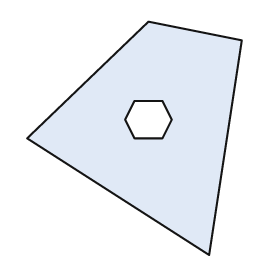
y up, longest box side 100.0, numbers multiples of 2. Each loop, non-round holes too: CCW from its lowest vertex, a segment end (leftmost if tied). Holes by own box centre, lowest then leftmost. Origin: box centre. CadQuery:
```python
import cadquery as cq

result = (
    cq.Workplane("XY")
    .moveTo(32.0, -50.0)
    .lineTo(46.0, 42.0)
    .lineTo(6.0, 50.0)
    .lineTo(-46.0, 0.0)
    .close()
    .moveTo(0.0, 0.0)
    .lineTo(12.0, 0.0)
    .lineTo(16.0, 8.0)
    .lineTo(12.0, 16.0)
    .lineTo(0.0, 16.0)
    .lineTo(-4.0, 8.0)
    .close()
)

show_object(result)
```